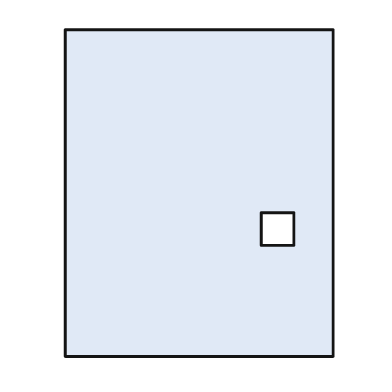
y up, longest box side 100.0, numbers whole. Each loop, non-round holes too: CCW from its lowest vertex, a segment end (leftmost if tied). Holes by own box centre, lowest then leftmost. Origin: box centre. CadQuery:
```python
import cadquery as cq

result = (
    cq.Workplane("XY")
    .moveTo(-41.0, -50.0)
    .lineTo(41.0, -50.0)
    .lineTo(41.0, 50.0)
    .lineTo(-41.0, 50.0)
    .close()
    .moveTo(19.0, -16.0)
    .lineTo(29.0, -16.0)
    .lineTo(29.0, -6.0)
    .lineTo(19.0, -6.0)
    .close()
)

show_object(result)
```